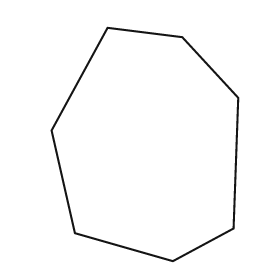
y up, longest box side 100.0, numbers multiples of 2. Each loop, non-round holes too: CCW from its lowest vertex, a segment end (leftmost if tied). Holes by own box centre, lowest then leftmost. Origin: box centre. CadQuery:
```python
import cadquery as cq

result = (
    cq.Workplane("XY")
    .moveTo(12.0, -50.0)
    .lineTo(38.0, -36.0)
    .lineTo(40.0, 20.0)
    .lineTo(16.0, 46.0)
    .lineTo(-16.0, 50.0)
    .lineTo(-40.0, 6.0)
    .lineTo(-30.0, -38.0)
    .close()
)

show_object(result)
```